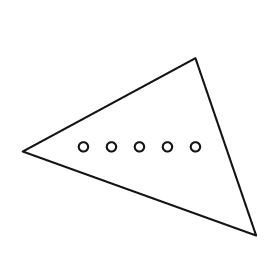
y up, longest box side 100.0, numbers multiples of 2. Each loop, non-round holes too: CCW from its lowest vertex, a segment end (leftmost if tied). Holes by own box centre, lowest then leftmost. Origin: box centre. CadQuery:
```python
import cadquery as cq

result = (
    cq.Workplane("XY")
    .moveTo(50.0, -38.0)
    .lineTo(24.0, 38.0)
    .lineTo(-50.0, -2.0)
    .close()
    .moveTo(-24.0, 0.0)
    .circle(2.0)
    .moveTo(-12.0, 0.0)
    .circle(2.0)
    .moveTo(0.0, 0.0)
    .circle(2.0)
    .moveTo(12.0, 0.0)
    .circle(2.0)
    .moveTo(24.0, 0.0)
    .circle(2.0)
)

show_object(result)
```